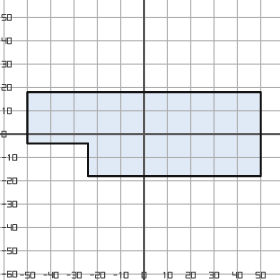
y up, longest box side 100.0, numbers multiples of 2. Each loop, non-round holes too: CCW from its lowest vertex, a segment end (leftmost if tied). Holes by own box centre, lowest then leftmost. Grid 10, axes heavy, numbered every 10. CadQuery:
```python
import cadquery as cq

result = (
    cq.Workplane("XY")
    .moveTo(-24.0, -18.0)
    .lineTo(50.0, -18.0)
    .lineTo(50.0, 18.0)
    .lineTo(-50.0, 18.0)
    .lineTo(-50.0, -4.0)
    .lineTo(-24.0, -4.0)
    .close()
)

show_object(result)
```